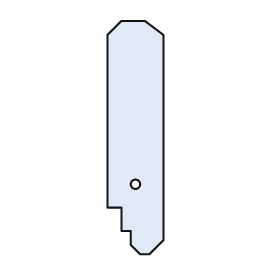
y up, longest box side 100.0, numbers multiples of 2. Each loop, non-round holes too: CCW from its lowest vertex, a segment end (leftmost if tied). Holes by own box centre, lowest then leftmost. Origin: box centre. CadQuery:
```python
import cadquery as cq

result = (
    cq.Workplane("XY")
    .moveTo(2.0, -50.0)
    .lineTo(6.0, -50.0)
    .lineTo(12.0, -44.0)
    .lineTo(12.0, 44.0)
    .lineTo(4.0, 50.0)
    .lineTo(-6.0, 50.0)
    .lineTo(-12.0, 44.0)
    .lineTo(-12.0, -30.0)
    .lineTo(-6.0, -30.0)
    .lineTo(-6.0, -40.0)
    .lineTo(-2.0, -40.0)
    .lineTo(-2.0, -46.0)
    .close()
    .moveTo(0.0, -20.0)
    .circle(2.0)
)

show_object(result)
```